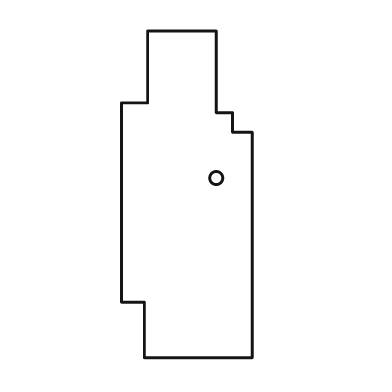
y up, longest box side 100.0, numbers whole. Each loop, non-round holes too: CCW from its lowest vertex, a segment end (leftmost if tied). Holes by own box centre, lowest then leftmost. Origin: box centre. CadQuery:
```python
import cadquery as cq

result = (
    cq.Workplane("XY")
    .moveTo(-13.0, -50.0)
    .lineTo(20.0, -50.0)
    .lineTo(20.0, 19.0)
    .lineTo(14.0, 19.0)
    .lineTo(14.0, 25.0)
    .lineTo(9.0, 25.0)
    .lineTo(9.0, 50.0)
    .lineTo(-12.0, 50.0)
    .lineTo(-12.0, 28.0)
    .lineTo(-20.0, 28.0)
    .lineTo(-20.0, -33.0)
    .lineTo(-13.0, -33.0)
    .close()
    .moveTo(9.0, 5.0)
    .circle(2.0)
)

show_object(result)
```